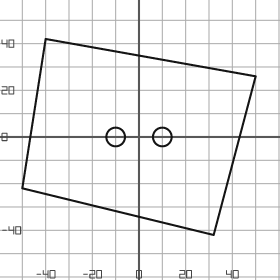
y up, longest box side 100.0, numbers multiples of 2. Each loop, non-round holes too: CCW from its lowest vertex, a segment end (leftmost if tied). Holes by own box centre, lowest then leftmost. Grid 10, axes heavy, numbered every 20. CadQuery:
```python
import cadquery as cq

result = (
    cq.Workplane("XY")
    .moveTo(32.0, -42.0)
    .lineTo(50.0, 26.0)
    .lineTo(-40.0, 42.0)
    .lineTo(-50.0, -22.0)
    .close()
    .moveTo(-10.0, 0.0)
    .circle(4.0)
    .moveTo(10.0, 0.0)
    .circle(4.0)
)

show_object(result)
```